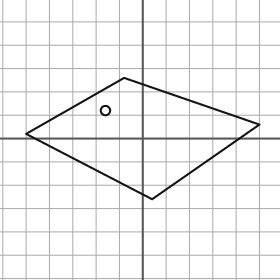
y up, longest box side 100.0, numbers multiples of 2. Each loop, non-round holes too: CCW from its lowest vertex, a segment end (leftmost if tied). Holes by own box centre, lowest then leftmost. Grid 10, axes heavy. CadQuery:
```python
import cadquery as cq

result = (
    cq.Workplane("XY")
    .moveTo(4.0, -26.0)
    .lineTo(50.0, 6.0)
    .lineTo(-8.0, 26.0)
    .lineTo(-50.0, 2.0)
    .close()
    .moveTo(-16.0, 12.0)
    .circle(2.0)
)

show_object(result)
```